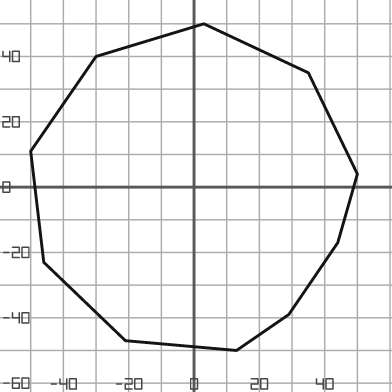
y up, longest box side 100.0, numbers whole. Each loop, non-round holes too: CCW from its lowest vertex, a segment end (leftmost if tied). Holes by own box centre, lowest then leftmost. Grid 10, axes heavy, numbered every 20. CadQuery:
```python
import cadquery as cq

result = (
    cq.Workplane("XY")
    .moveTo(13.0, -50.0)
    .lineTo(29.0, -39.0)
    .lineTo(44.0, -17.0)
    .lineTo(50.0, 4.0)
    .lineTo(35.0, 35.0)
    .lineTo(3.0, 50.0)
    .lineTo(-30.0, 40.0)
    .lineTo(-50.0, 11.0)
    .lineTo(-46.0, -23.0)
    .lineTo(-21.0, -47.0)
    .close()
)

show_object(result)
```